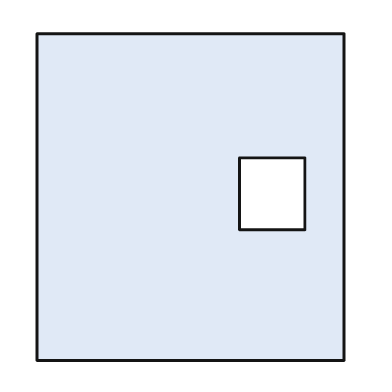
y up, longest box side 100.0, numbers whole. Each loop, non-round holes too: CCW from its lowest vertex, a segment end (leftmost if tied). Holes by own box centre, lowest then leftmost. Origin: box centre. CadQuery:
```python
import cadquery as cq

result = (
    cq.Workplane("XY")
    .moveTo(-47.0, -50.0)
    .lineTo(47.0, -50.0)
    .lineTo(47.0, 50.0)
    .lineTo(-47.0, 50.0)
    .close()
    .moveTo(15.0, -10.0)
    .lineTo(35.0, -10.0)
    .lineTo(35.0, 12.0)
    .lineTo(15.0, 12.0)
    .close()
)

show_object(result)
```